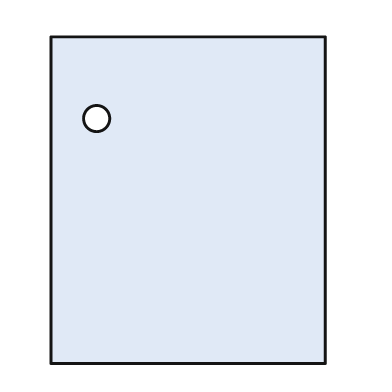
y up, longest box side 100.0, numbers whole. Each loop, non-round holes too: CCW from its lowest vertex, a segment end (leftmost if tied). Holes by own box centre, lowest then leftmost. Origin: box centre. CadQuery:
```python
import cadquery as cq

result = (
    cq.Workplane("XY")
    .moveTo(-42.0, -50.0)
    .lineTo(42.0, -50.0)
    .lineTo(42.0, 50.0)
    .lineTo(-42.0, 50.0)
    .close()
    .moveTo(-28.0, 25.0)
    .circle(4.0)
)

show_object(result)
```